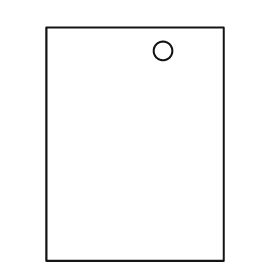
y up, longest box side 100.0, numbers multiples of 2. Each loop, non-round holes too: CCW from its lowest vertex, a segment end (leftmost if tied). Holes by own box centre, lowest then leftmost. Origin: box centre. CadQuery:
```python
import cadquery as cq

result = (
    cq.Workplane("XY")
    .moveTo(-38.0, -50.0)
    .lineTo(38.0, -50.0)
    .lineTo(38.0, 50.0)
    .lineTo(-38.0, 50.0)
    .close()
    .moveTo(12.0, 40.0)
    .circle(4.0)
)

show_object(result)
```